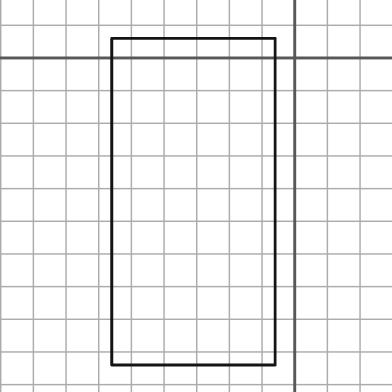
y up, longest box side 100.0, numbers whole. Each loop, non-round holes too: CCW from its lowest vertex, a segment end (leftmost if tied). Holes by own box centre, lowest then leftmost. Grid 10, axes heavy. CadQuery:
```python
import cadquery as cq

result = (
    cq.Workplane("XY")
    .moveTo(-56.0, -94.0)
    .lineTo(-6.0, -94.0)
    .lineTo(-6.0, 6.0)
    .lineTo(-56.0, 6.0)
    .close()
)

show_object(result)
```